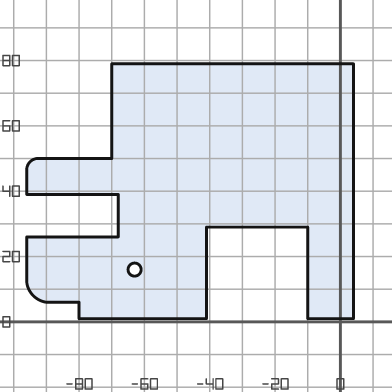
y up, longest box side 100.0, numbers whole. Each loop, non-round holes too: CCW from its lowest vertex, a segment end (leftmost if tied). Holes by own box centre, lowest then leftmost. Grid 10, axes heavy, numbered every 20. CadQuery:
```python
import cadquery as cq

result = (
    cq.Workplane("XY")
    .moveTo(-80.0, 1.0)
    .lineTo(-41.0, 1.0)
    .lineTo(-41.0, 29.0)
    .lineTo(-10.0, 29.0)
    .lineTo(-10.0, 1.0)
    .lineTo(4.0, 1.0)
    .lineTo(4.0, 79.0)
    .lineTo(-70.0, 79.0)
    .lineTo(-70.0, 50.0)
    .lineTo(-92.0, 50.0)
    .threePointArc((-95.0, 49.0), (-96.0, 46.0))
    .lineTo(-96.0, 39.0)
    .lineTo(-68.0, 39.0)
    .lineTo(-68.0, 26.0)
    .lineTo(-96.0, 26.0)
    .lineTo(-96.0, 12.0)
    .threePointArc((-94.0, 8.0), (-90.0, 6.0))
    .lineTo(-80.0, 6.0)
    .close()
    .moveTo(-63.0, 16.0)
    .circle(2.0)
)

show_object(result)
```